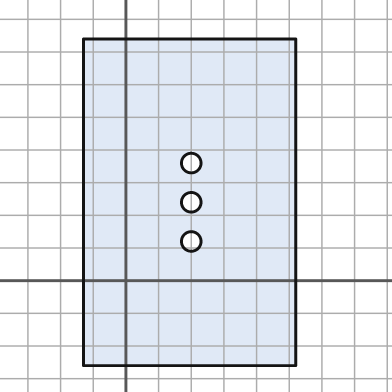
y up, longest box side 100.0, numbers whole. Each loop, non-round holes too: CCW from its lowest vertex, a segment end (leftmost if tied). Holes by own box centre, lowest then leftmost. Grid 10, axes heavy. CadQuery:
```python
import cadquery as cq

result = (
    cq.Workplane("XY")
    .moveTo(-13.0, -26.0)
    .lineTo(52.0, -26.0)
    .lineTo(52.0, 74.0)
    .lineTo(-13.0, 74.0)
    .close()
    .moveTo(20.0, 12.0)
    .circle(3.0)
    .moveTo(20.0, 24.0)
    .circle(3.0)
    .moveTo(20.0, 36.0)
    .circle(3.0)
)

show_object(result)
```